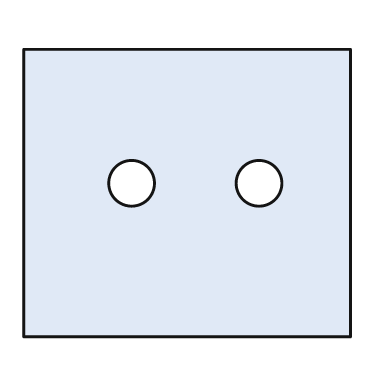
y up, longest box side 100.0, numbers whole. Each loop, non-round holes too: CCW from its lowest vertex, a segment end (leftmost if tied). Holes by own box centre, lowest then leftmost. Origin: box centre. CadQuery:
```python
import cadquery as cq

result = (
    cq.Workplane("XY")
    .moveTo(-50.0, -44.0)
    .lineTo(50.0, -44.0)
    .lineTo(50.0, 44.0)
    .lineTo(-50.0, 44.0)
    .close()
    .moveTo(-17.0, 3.0)
    .circle(7.0)
    .moveTo(22.0, 3.0)
    .circle(7.0)
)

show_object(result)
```